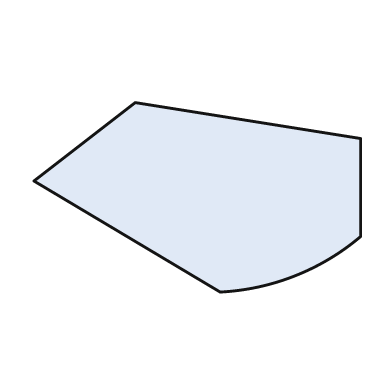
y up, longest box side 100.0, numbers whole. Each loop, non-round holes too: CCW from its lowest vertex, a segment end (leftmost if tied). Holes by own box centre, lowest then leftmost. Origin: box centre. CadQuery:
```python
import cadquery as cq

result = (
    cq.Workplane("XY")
    .moveTo(7.0, -29.0)
    .threePointArc((30.0, -24.0), (50.0, -12.0))
    .lineTo(50.0, 18.0)
    .lineTo(-19.0, 29.0)
    .lineTo(-50.0, 5.0)
    .close()
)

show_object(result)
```